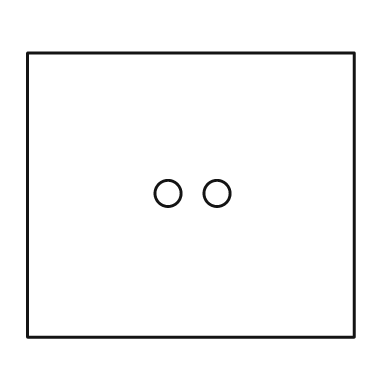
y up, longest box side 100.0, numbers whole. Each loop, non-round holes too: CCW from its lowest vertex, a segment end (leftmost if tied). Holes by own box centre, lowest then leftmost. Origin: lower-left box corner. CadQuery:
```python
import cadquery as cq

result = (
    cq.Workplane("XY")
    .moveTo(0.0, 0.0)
    .lineTo(100.0, 0.0)
    .lineTo(100.0, 87.0)
    .lineTo(0.0, 87.0)
    .close()
    .moveTo(43.0, 44.0)
    .circle(4.0)
    .moveTo(58.0, 44.0)
    .circle(4.0)
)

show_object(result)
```